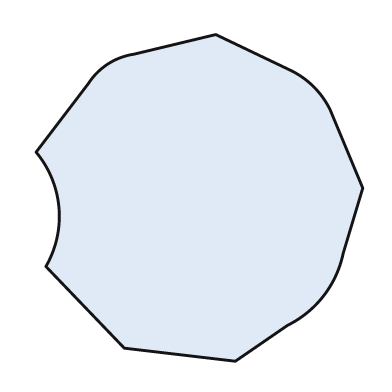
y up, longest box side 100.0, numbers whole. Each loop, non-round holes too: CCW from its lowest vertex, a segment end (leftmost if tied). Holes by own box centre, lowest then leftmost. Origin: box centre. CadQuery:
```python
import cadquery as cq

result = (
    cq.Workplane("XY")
    .moveTo(11.0, -50.0)
    .lineTo(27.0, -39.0)
    .threePointArc((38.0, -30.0), (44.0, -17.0))
    .lineTo(50.0, 3.0)
    .lineTo(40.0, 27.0)
    .threePointArc((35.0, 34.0), (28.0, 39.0))
    .lineTo(5.0, 50.0)
    .lineTo(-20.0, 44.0)
    .threePointArc((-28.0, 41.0), (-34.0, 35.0))
    .lineTo(-50.0, 14.0)
    .threePointArc((-43.0, -3.0), (-47.0, -21.0))
    .lineTo(-23.0, -46.0)
    .close()
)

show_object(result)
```